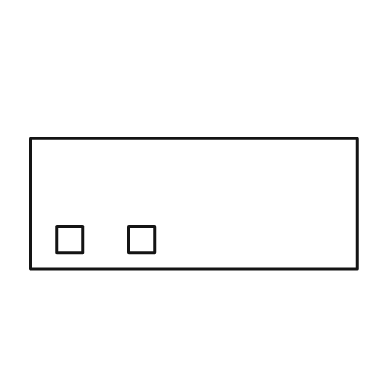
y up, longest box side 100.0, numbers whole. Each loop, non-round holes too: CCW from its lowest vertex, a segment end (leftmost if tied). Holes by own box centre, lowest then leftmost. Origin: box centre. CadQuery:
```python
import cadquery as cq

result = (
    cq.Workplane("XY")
    .moveTo(-50.0, -20.0)
    .lineTo(50.0, -20.0)
    .lineTo(50.0, 20.0)
    .lineTo(-50.0, 20.0)
    .close()
    .moveTo(-42.0, -15.0)
    .lineTo(-34.0, -15.0)
    .lineTo(-34.0, -7.0)
    .lineTo(-42.0, -7.0)
    .close()
    .moveTo(-20.0, -15.0)
    .lineTo(-12.0, -15.0)
    .lineTo(-12.0, -7.0)
    .lineTo(-20.0, -7.0)
    .close()
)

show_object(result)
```